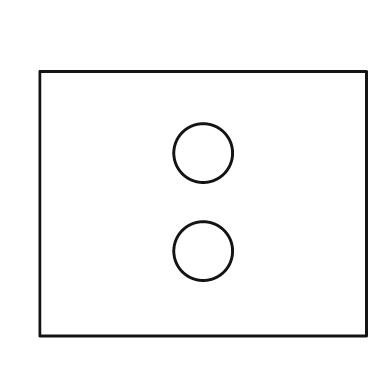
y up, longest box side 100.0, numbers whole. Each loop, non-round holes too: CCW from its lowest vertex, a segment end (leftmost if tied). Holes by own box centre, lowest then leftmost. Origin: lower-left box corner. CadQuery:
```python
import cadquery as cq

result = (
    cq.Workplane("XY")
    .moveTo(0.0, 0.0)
    .lineTo(100.0, 0.0)
    .lineTo(100.0, 81.0)
    .lineTo(0.0, 81.0)
    .close()
    .moveTo(50.0, 26.0)
    .circle(9.0)
    .moveTo(50.0, 56.0)
    .circle(9.0)
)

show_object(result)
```